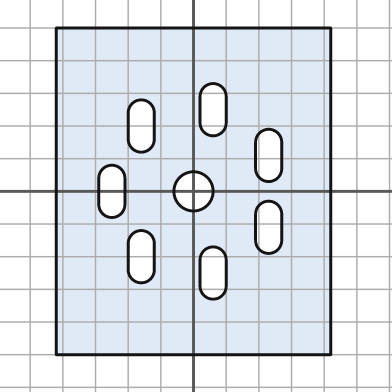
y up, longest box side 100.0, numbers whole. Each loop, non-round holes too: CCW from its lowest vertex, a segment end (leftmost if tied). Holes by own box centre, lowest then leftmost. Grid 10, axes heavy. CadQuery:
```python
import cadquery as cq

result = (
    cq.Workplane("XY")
    .moveTo(-42.0, -50.0)
    .lineTo(42.0, -50.0)
    .lineTo(42.0, 50.0)
    .lineTo(-42.0, 50.0)
    .close()
    .moveTo(2.0, -29.0)
    .threePointArc((6.0, -33.0), (10.0, -29.0))
    .lineTo(10.0, -21.0)
    .threePointArc((6.0, -17.0), (2.0, -21.0))
    .close()
    .moveTo(-20.0, -24.0)
    .threePointArc((-16.0, -28.0), (-12.0, -24.0))
    .lineTo(-12.0, -16.0)
    .threePointArc((-16.0, -12.0), (-20.0, -16.0))
    .close()
    .moveTo(19.0, -15.0)
    .threePointArc((23.0, -19.0), (27.0, -15.0))
    .lineTo(27.0, -7.0)
    .threePointArc((23.0, -3.0), (19.0, -7.0))
    .close()
    .moveTo(-29.0, -4.0)
    .threePointArc((-25.0, -8.0), (-21.0, -4.0))
    .lineTo(-21.0, 4.0)
    .threePointArc((-25.0, 8.0), (-29.0, 4.0))
    .close()
    .moveTo(0.0, 0.0)
    .circle(6.0)
    .moveTo(19.0, 7.0)
    .threePointArc((23.0, 3.0), (27.0, 7.0))
    .lineTo(27.0, 15.0)
    .threePointArc((23.0, 19.0), (19.0, 15.0))
    .close()
    .moveTo(-20.0, 16.0)
    .threePointArc((-16.0, 12.0), (-12.0, 16.0))
    .lineTo(-12.0, 24.0)
    .threePointArc((-16.0, 28.0), (-20.0, 24.0))
    .close()
    .moveTo(2.0, 21.0)
    .threePointArc((6.0, 17.0), (10.0, 21.0))
    .lineTo(10.0, 29.0)
    .threePointArc((6.0, 33.0), (2.0, 29.0))
    .close()
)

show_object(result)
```